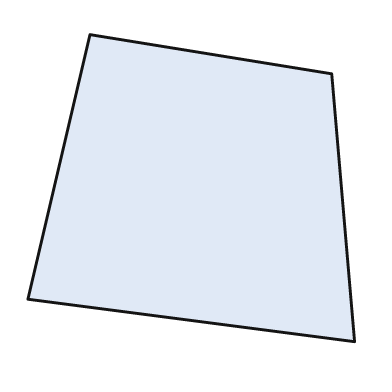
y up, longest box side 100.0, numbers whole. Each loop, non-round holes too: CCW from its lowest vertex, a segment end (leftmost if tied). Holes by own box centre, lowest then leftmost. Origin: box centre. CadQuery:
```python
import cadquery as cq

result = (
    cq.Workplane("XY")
    .moveTo(50.0, -47.0)
    .lineTo(43.0, 35.0)
    .lineTo(-31.0, 47.0)
    .lineTo(-50.0, -34.0)
    .close()
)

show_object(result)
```